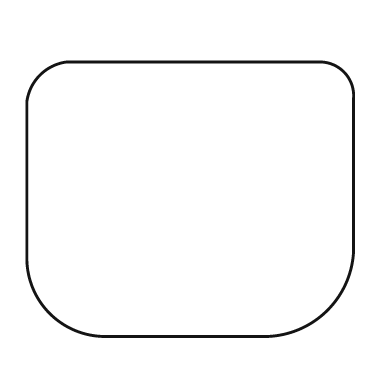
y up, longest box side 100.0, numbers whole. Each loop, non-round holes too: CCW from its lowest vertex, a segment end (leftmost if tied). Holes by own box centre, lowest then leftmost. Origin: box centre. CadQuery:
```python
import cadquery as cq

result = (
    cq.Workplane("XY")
    .moveTo(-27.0, -42.0)
    .lineTo(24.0, -42.0)
    .threePointArc((42.0, -34.0), (50.0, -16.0))
    .lineTo(50.0, 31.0)
    .threePointArc((47.0, 39.0), (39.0, 42.0))
    .lineTo(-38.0, 42.0)
    .threePointArc((-46.0, 38.0), (-50.0, 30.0))
    .lineTo(-50.0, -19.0)
    .threePointArc((-43.0, -35.0), (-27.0, -42.0))
    .close()
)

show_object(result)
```